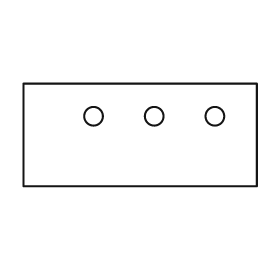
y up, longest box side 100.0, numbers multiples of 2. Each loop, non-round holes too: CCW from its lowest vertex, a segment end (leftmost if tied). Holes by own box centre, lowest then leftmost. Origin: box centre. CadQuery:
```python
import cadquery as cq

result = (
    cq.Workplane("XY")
    .moveTo(-50.0, -22.0)
    .lineTo(50.0, -22.0)
    .lineTo(50.0, 22.0)
    .lineTo(-50.0, 22.0)
    .close()
    .moveTo(-20.0, 8.0)
    .circle(4.0)
    .moveTo(6.0, 8.0)
    .circle(4.0)
    .moveTo(32.0, 8.0)
    .circle(4.0)
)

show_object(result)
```